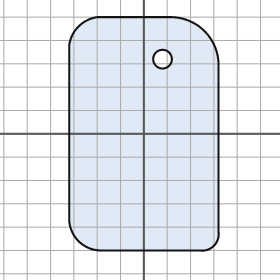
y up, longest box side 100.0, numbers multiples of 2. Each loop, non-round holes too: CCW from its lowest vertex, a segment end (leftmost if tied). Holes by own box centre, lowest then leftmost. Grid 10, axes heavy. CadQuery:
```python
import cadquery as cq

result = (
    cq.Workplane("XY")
    .moveTo(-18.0, -50.0)
    .lineTo(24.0, -50.0)
    .threePointArc((30.0, -48.0), (32.0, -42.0))
    .lineTo(32.0, 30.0)
    .threePointArc((26.0, 44.0), (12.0, 50.0))
    .lineTo(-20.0, 50.0)
    .threePointArc((-28.0, 46.0), (-32.0, 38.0))
    .lineTo(-32.0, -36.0)
    .threePointArc((-28.0, -46.0), (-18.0, -50.0))
    .close()
    .moveTo(8.0, 32.0)
    .circle(4.0)
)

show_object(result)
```